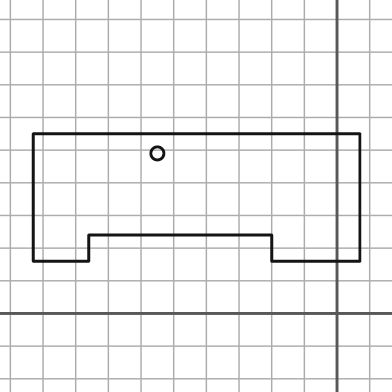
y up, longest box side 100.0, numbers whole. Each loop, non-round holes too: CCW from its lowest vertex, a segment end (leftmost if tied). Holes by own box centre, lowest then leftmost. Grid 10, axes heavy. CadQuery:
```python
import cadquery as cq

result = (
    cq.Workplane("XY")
    .moveTo(-93.0, 16.0)
    .lineTo(-76.0, 16.0)
    .lineTo(-76.0, 24.0)
    .lineTo(-20.0, 24.0)
    .lineTo(-20.0, 16.0)
    .lineTo(7.0, 16.0)
    .lineTo(7.0, 55.0)
    .lineTo(-93.0, 55.0)
    .close()
    .moveTo(-55.0, 49.0)
    .circle(2.0)
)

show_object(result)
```